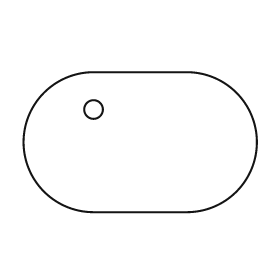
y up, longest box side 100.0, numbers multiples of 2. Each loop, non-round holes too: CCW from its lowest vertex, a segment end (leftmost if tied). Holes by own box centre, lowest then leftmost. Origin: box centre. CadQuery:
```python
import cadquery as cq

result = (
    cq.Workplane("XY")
    .moveTo(-20.0, -30.0)
    .lineTo(20.0, -30.0)
    .threePointArc((50.0, 0.0), (20.0, 30.0))
    .lineTo(-20.0, 30.0)
    .threePointArc((-50.0, 0.0), (-20.0, -30.0))
    .close()
    .moveTo(-20.0, 14.0)
    .circle(4.0)
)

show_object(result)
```